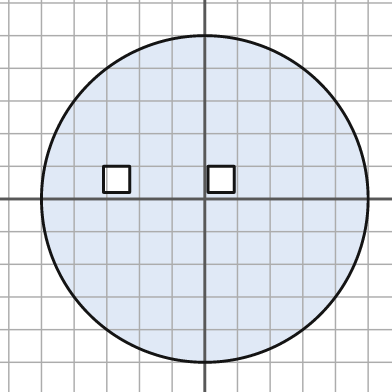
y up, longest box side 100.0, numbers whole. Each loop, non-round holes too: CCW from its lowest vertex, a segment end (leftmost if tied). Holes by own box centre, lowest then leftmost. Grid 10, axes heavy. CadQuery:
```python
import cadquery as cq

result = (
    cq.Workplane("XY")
    .moveTo(0.0, 0.0)
    .circle(50.0)
    .moveTo(-31.0, 2.0)
    .lineTo(-23.0, 2.0)
    .lineTo(-23.0, 10.0)
    .lineTo(-31.0, 10.0)
    .close()
    .moveTo(1.0, 2.0)
    .lineTo(9.0, 2.0)
    .lineTo(9.0, 10.0)
    .lineTo(1.0, 10.0)
    .close()
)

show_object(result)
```